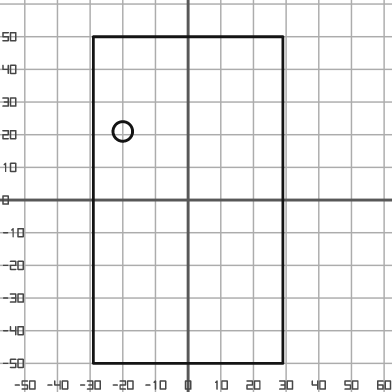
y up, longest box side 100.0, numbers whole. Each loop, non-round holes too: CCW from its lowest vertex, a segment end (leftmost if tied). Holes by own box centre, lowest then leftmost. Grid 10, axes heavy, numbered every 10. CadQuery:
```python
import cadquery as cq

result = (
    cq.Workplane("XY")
    .moveTo(-29.0, -50.0)
    .lineTo(29.0, -50.0)
    .lineTo(29.0, 50.0)
    .lineTo(-29.0, 50.0)
    .close()
    .moveTo(-20.0, 21.0)
    .circle(3.0)
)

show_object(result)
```